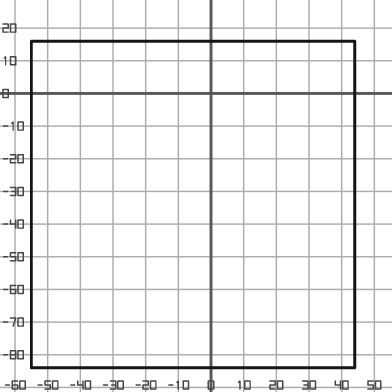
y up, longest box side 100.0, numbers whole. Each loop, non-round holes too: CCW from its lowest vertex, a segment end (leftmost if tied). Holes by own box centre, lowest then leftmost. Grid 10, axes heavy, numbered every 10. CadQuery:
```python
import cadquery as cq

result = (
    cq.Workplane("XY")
    .moveTo(-55.0, -84.0)
    .lineTo(44.0, -84.0)
    .lineTo(44.0, 16.0)
    .lineTo(-55.0, 16.0)
    .close()
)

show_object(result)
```